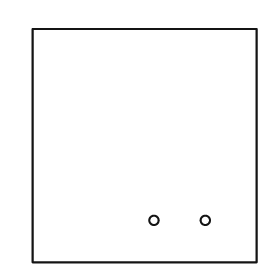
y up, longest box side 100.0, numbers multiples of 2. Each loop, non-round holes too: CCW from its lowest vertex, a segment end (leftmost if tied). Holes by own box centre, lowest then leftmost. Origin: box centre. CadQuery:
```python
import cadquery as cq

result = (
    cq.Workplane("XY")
    .moveTo(-48.0, -50.0)
    .lineTo(48.0, -50.0)
    .lineTo(48.0, 50.0)
    .lineTo(-48.0, 50.0)
    .close()
    .moveTo(4.0, -32.0)
    .circle(2.0)
    .moveTo(26.0, -32.0)
    .circle(2.0)
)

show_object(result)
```